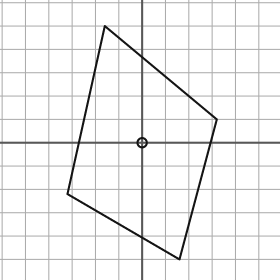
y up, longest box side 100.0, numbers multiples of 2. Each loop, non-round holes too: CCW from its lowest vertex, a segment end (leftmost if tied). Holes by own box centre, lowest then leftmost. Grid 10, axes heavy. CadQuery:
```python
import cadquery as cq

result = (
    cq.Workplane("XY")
    .moveTo(16.0, -50.0)
    .lineTo(32.0, 10.0)
    .lineTo(-16.0, 50.0)
    .lineTo(-32.0, -22.0)
    .close()
    .moveTo(0.0, 0.0)
    .circle(2.0)
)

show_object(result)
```